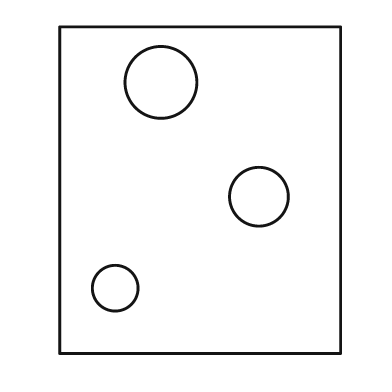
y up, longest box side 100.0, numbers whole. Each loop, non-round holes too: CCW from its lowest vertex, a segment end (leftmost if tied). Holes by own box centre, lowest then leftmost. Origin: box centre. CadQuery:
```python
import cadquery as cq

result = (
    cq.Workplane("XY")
    .moveTo(-43.0, -50.0)
    .lineTo(43.0, -50.0)
    .lineTo(43.0, 50.0)
    .lineTo(-43.0, 50.0)
    .close()
    .moveTo(-26.0, -30.0)
    .circle(7.0)
    .moveTo(18.0, -2.0)
    .circle(9.0)
    .moveTo(-12.0, 33.0)
    .circle(11.0)
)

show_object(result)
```